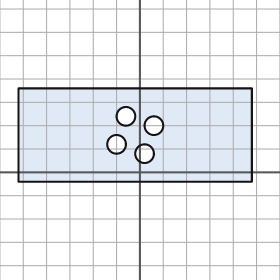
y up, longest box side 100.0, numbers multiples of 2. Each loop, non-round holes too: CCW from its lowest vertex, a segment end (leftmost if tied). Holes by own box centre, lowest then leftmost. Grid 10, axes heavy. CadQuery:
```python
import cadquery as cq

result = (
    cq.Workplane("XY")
    .moveTo(-52.0, -4.0)
    .lineTo(48.0, -4.0)
    .lineTo(48.0, 36.0)
    .lineTo(-52.0, 36.0)
    .close()
    .moveTo(2.0, 8.0)
    .circle(4.0)
    .moveTo(-10.0, 12.0)
    .circle(4.0)
    .moveTo(6.0, 20.0)
    .circle(4.0)
    .moveTo(-6.0, 24.0)
    .circle(4.0)
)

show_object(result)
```